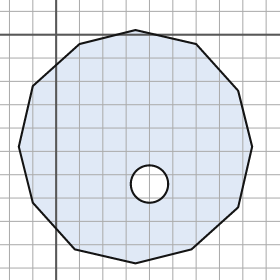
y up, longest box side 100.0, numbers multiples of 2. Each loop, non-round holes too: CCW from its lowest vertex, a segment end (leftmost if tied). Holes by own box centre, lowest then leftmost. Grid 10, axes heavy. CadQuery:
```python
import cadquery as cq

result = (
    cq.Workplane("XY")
    .moveTo(34.0, -98.0)
    .lineTo(58.0, -92.0)
    .lineTo(78.0, -74.0)
    .lineTo(84.0, -48.0)
    .lineTo(78.0, -24.0)
    .lineTo(60.0, -4.0)
    .lineTo(34.0, 2.0)
    .lineTo(10.0, -4.0)
    .lineTo(-10.0, -22.0)
    .lineTo(-16.0, -48.0)
    .lineTo(-10.0, -72.0)
    .lineTo(8.0, -92.0)
    .close()
    .moveTo(40.0, -64.0)
    .circle(8.0)
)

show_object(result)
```